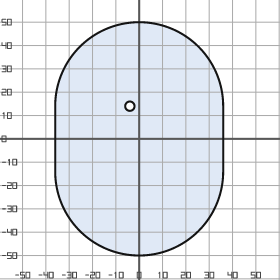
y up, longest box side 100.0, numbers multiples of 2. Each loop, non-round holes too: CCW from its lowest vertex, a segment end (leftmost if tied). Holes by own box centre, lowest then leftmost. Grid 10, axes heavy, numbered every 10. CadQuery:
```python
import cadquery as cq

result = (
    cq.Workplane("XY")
    .moveTo(-36.0, -14.0)
    .threePointArc((0.0, -50.0), (36.0, -14.0))
    .lineTo(36.0, 14.0)
    .threePointArc((0.0, 50.0), (-36.0, 14.0))
    .close()
    .moveTo(-4.0, 14.0)
    .circle(2.0)
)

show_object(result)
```